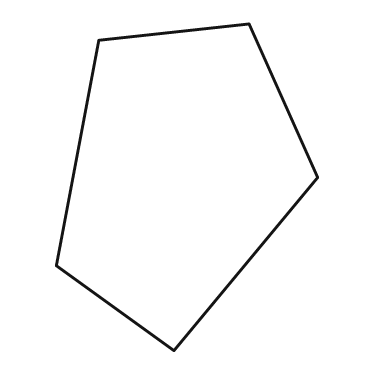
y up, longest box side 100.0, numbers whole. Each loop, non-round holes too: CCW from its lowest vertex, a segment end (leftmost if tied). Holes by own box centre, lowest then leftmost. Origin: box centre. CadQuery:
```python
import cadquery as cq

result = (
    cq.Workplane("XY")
    .moveTo(-4.0, -50.0)
    .lineTo(40.0, 3.0)
    .lineTo(19.0, 50.0)
    .lineTo(-27.0, 45.0)
    .lineTo(-40.0, -24.0)
    .close()
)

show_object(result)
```